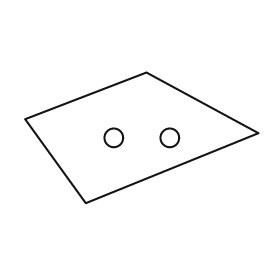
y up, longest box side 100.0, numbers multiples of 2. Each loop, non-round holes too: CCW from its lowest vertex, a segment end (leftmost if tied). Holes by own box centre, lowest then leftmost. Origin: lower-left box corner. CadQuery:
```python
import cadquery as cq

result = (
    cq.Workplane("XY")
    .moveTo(26.0, 0.0)
    .lineTo(100.0, 30.0)
    .lineTo(52.0, 56.0)
    .lineTo(0.0, 36.0)
    .close()
    .moveTo(38.0, 28.0)
    .circle(4.0)
    .moveTo(62.0, 28.0)
    .circle(4.0)
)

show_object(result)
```